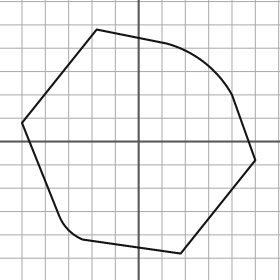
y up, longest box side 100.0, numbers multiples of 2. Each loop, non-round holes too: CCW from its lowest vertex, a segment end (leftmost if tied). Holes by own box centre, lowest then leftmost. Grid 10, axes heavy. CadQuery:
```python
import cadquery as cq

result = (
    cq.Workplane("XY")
    .moveTo(18.0, -48.0)
    .lineTo(50.0, -8.0)
    .lineTo(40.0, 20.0)
    .threePointArc((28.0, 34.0), (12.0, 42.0))
    .lineTo(-18.0, 48.0)
    .lineTo(-50.0, 8.0)
    .lineTo(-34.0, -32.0)
    .threePointArc((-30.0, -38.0), (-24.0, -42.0))
    .close()
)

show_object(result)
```